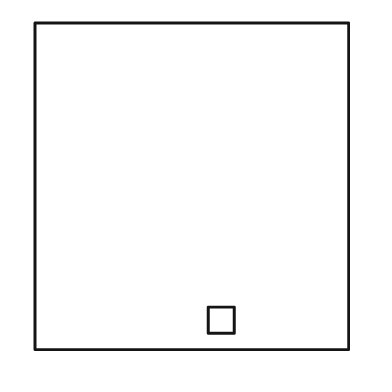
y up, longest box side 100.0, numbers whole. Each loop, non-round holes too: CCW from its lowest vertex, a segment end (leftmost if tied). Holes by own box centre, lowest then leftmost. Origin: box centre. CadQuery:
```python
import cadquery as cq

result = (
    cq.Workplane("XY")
    .moveTo(-48.0, -50.0)
    .lineTo(48.0, -50.0)
    .lineTo(48.0, 50.0)
    .lineTo(-48.0, 50.0)
    .close()
    .moveTo(5.0, -45.0)
    .lineTo(13.0, -45.0)
    .lineTo(13.0, -37.0)
    .lineTo(5.0, -37.0)
    .close()
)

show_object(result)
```